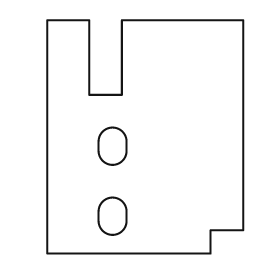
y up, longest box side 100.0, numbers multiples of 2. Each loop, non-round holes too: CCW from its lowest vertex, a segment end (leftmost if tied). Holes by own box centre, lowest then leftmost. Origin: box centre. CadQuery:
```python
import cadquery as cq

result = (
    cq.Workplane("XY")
    .moveTo(-42.0, -50.0)
    .lineTo(28.0, -50.0)
    .lineTo(28.0, -40.0)
    .lineTo(42.0, -40.0)
    .lineTo(42.0, 50.0)
    .lineTo(-10.0, 50.0)
    .lineTo(-10.0, 18.0)
    .lineTo(-24.0, 18.0)
    .lineTo(-24.0, 50.0)
    .lineTo(-42.0, 50.0)
    .close()
    .moveTo(-20.0, -36.0)
    .threePointArc((-14.0, -42.0), (-8.0, -36.0))
    .lineTo(-8.0, -32.0)
    .threePointArc((-14.0, -26.0), (-20.0, -32.0))
    .close()
    .moveTo(-20.0, -6.0)
    .threePointArc((-14.0, -12.0), (-8.0, -6.0))
    .lineTo(-8.0, -2.0)
    .threePointArc((-14.0, 4.0), (-20.0, -2.0))
    .close()
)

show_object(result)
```